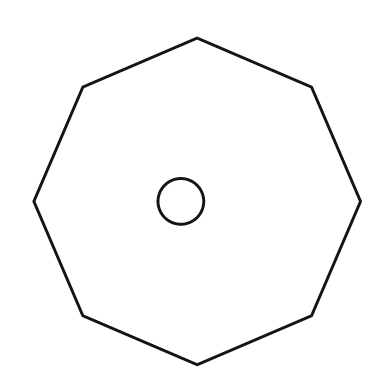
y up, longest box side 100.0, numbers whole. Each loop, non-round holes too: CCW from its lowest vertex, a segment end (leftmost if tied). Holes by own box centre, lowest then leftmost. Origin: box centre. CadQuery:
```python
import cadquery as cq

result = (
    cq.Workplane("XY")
    .moveTo(0.0, -50.0)
    .lineTo(35.0, -35.0)
    .lineTo(50.0, 0.0)
    .lineTo(35.0, 35.0)
    .lineTo(0.0, 50.0)
    .lineTo(-35.0, 35.0)
    .lineTo(-50.0, 0.0)
    .lineTo(-35.0, -35.0)
    .close()
    .moveTo(-5.0, 0.0)
    .circle(7.0)
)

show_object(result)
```